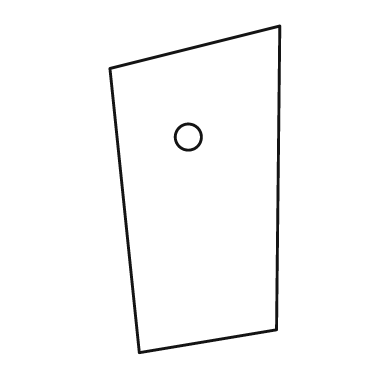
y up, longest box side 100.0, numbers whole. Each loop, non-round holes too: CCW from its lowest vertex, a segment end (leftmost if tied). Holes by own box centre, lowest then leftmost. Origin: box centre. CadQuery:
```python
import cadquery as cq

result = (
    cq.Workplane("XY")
    .moveTo(-17.0, -50.0)
    .lineTo(25.0, -43.0)
    .lineTo(26.0, 50.0)
    .lineTo(-26.0, 37.0)
    .close()
    .moveTo(-2.0, 16.0)
    .circle(4.0)
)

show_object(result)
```